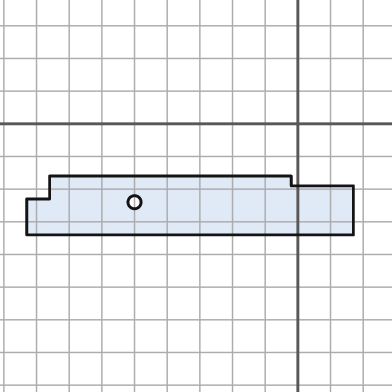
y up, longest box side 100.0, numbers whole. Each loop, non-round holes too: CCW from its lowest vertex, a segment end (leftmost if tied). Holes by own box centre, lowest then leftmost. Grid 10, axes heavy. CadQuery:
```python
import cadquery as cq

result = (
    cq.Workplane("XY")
    .moveTo(-83.0, -34.0)
    .lineTo(17.0, -34.0)
    .lineTo(17.0, -19.0)
    .lineTo(-2.0, -19.0)
    .lineTo(-2.0, -16.0)
    .lineTo(-76.0, -16.0)
    .lineTo(-76.0, -23.0)
    .lineTo(-83.0, -23.0)
    .close()
    .moveTo(-50.0, -24.0)
    .circle(2.0)
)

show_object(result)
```